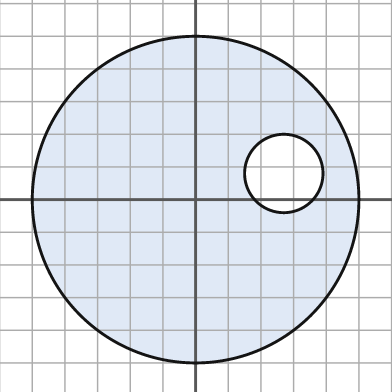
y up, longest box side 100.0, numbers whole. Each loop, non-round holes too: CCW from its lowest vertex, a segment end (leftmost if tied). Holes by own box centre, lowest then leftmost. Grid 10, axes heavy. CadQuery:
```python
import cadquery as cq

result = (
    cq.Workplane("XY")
    .moveTo(0.0, 0.0)
    .circle(50.0)
    .moveTo(27.0, 8.0)
    .circle(12.0)
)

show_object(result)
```